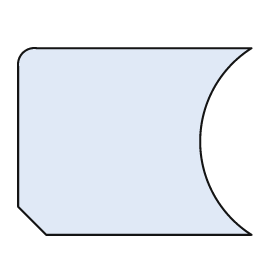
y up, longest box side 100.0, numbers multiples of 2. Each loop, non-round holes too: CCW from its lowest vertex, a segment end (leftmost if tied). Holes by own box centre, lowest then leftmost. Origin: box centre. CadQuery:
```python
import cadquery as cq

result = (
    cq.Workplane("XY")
    .moveTo(-38.0, -40.0)
    .lineTo(50.0, -40.0)
    .threePointArc((28.0, 0.0), (50.0, 40.0))
    .lineTo(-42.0, 40.0)
    .threePointArc((-48.0, 38.0), (-50.0, 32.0))
    .lineTo(-50.0, -28.0)
    .close()
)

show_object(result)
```